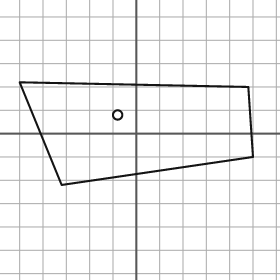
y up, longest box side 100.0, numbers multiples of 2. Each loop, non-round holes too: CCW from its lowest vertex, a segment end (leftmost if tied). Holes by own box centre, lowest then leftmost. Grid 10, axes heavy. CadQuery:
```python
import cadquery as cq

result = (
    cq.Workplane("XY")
    .moveTo(-32.0, -22.0)
    .lineTo(50.0, -10.0)
    .lineTo(48.0, 20.0)
    .lineTo(-50.0, 22.0)
    .close()
    .moveTo(-8.0, 8.0)
    .circle(2.0)
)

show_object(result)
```